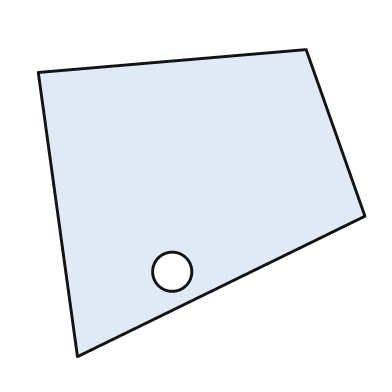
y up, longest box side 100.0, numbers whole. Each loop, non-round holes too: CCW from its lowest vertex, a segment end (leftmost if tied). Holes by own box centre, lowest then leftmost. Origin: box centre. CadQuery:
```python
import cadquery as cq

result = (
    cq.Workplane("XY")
    .moveTo(-38.0, -47.0)
    .lineTo(50.0, -4.0)
    .lineTo(32.0, 47.0)
    .lineTo(-50.0, 40.0)
    .close()
    .moveTo(-9.0, -21.0)
    .circle(6.0)
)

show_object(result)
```